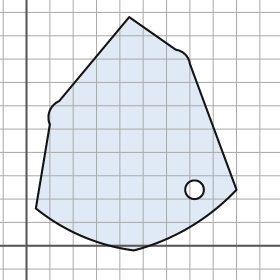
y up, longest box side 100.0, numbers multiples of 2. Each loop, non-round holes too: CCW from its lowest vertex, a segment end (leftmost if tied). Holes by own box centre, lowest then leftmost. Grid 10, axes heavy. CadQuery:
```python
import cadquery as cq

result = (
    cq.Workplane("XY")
    .moveTo(46.0, -2.0)
    .threePointArc((70.0, 8.0), (90.0, 24.0))
    .lineTo(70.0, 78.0)
    .threePointArc((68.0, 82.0), (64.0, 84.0))
    .lineTo(44.0, 98.0)
    .lineTo(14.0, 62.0)
    .threePointArc((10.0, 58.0), (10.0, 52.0))
    .lineTo(4.0, 16.0)
    .threePointArc((24.0, 4.0), (46.0, -2.0))
    .close()
    .moveTo(72.0, 24.0)
    .circle(4.0)
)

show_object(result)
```